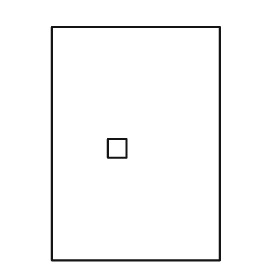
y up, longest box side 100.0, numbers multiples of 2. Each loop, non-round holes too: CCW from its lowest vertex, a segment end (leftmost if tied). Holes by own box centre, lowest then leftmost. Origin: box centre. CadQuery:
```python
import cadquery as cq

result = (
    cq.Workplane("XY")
    .moveTo(-36.0, -50.0)
    .lineTo(36.0, -50.0)
    .lineTo(36.0, 50.0)
    .lineTo(-36.0, 50.0)
    .close()
    .moveTo(-12.0, -6.0)
    .lineTo(-4.0, -6.0)
    .lineTo(-4.0, 2.0)
    .lineTo(-12.0, 2.0)
    .close()
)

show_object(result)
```